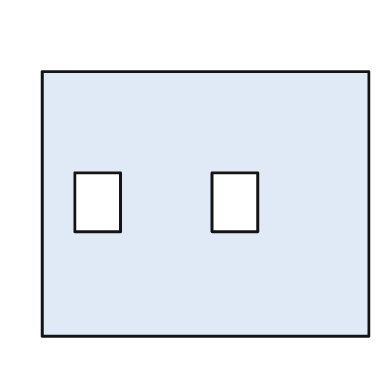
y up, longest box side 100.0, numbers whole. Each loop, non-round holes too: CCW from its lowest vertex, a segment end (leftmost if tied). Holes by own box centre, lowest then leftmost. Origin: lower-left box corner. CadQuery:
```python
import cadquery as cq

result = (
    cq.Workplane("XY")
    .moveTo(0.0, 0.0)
    .lineTo(100.0, 0.0)
    .lineTo(100.0, 81.0)
    .lineTo(0.0, 81.0)
    .close()
    .moveTo(10.0, 32.0)
    .lineTo(24.0, 32.0)
    .lineTo(24.0, 50.0)
    .lineTo(10.0, 50.0)
    .close()
    .moveTo(52.0, 32.0)
    .lineTo(66.0, 32.0)
    .lineTo(66.0, 50.0)
    .lineTo(52.0, 50.0)
    .close()
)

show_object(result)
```